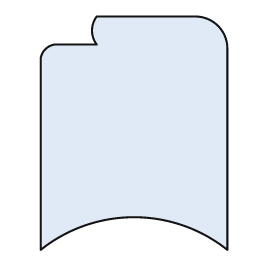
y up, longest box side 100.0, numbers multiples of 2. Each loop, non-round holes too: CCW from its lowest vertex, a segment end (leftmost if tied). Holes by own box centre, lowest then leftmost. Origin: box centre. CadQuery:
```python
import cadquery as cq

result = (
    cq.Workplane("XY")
    .moveTo(-40.0, -50.0)
    .threePointArc((0.0, -36.0), (40.0, -50.0))
    .lineTo(40.0, 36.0)
    .threePointArc((36.0, 46.0), (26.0, 50.0))
    .lineTo(-16.0, 50.0)
    .threePointArc((-18.0, 44.0), (-16.0, 38.0))
    .lineTo(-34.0, 38.0)
    .threePointArc((-38.0, 36.0), (-40.0, 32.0))
    .close()
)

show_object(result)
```